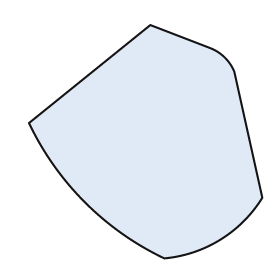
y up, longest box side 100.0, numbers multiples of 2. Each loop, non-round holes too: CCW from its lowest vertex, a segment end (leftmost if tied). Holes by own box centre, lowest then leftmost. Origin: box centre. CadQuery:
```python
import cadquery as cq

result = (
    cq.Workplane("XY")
    .moveTo(8.0, -50.0)
    .threePointArc((32.0, -42.0), (50.0, -24.0))
    .lineTo(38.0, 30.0)
    .threePointArc((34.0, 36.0), (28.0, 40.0))
    .lineTo(2.0, 50.0)
    .lineTo(-50.0, 8.0)
    .threePointArc((-26.0, -26.0), (8.0, -50.0))
    .close()
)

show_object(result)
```